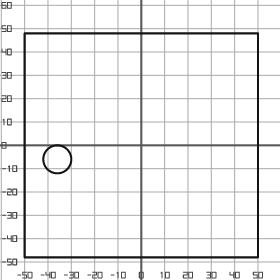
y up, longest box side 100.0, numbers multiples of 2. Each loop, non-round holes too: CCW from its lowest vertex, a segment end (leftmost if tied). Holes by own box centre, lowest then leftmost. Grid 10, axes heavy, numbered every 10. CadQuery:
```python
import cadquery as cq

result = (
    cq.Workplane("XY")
    .moveTo(-50.0, -48.0)
    .lineTo(50.0, -48.0)
    .lineTo(50.0, 48.0)
    .lineTo(-50.0, 48.0)
    .close()
    .moveTo(-36.0, -6.0)
    .circle(6.0)
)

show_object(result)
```